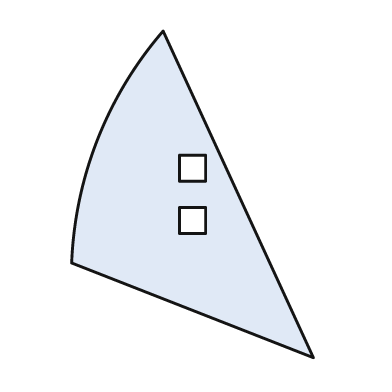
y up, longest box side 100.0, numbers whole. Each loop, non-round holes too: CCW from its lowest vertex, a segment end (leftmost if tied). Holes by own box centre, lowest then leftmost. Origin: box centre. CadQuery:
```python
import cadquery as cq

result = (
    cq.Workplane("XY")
    .moveTo(37.0, -50.0)
    .lineTo(-9.0, 50.0)
    .threePointArc((-29.0, 17.0), (-37.0, -21.0))
    .close()
    .moveTo(-4.0, -12.0)
    .lineTo(4.0, -12.0)
    .lineTo(4.0, -4.0)
    .lineTo(-4.0, -4.0)
    .close()
    .moveTo(-4.0, 4.0)
    .lineTo(4.0, 4.0)
    .lineTo(4.0, 12.0)
    .lineTo(-4.0, 12.0)
    .close()
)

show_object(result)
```